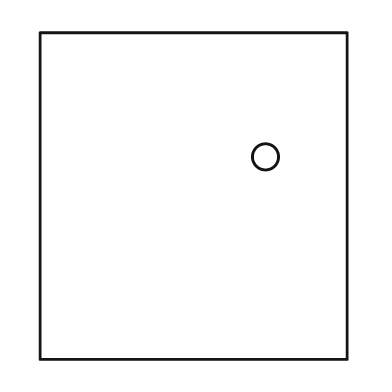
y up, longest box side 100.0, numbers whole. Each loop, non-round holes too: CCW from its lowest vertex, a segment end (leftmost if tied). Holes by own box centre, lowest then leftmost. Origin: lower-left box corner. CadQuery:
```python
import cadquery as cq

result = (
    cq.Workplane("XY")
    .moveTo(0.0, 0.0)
    .lineTo(94.0, 0.0)
    .lineTo(94.0, 100.0)
    .lineTo(0.0, 100.0)
    .close()
    .moveTo(69.0, 62.0)
    .circle(4.0)
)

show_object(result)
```